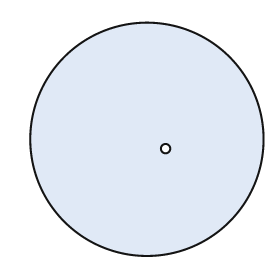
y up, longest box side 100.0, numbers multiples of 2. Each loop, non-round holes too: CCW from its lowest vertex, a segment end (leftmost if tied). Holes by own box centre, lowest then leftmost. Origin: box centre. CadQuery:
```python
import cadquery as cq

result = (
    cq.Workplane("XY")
    .moveTo(0.0, 0.0)
    .circle(50.0)
    .moveTo(8.0, -4.0)
    .circle(2.0)
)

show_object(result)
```